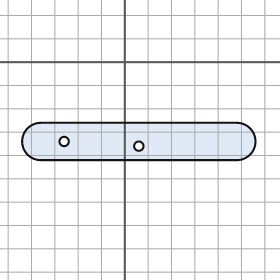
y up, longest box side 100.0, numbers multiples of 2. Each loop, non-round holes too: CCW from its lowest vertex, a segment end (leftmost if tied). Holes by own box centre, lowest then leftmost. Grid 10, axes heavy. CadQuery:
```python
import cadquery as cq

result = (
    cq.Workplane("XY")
    .moveTo(-36.0, -42.0)
    .lineTo(48.0, -42.0)
    .threePointArc((56.0, -34.0), (48.0, -26.0))
    .lineTo(-36.0, -26.0)
    .threePointArc((-44.0, -34.0), (-36.0, -42.0))
    .close()
    .moveTo(6.0, -36.0)
    .circle(2.0)
    .moveTo(-26.0, -34.0)
    .circle(2.0)
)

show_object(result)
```